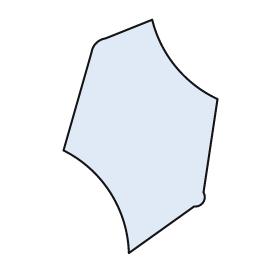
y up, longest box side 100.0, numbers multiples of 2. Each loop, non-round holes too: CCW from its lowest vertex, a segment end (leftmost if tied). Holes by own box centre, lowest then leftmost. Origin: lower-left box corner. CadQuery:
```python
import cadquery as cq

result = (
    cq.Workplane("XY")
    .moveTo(28.0, 0.0)
    .lineTo(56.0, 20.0)
    .threePointArc((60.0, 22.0), (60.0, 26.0))
    .lineTo(66.0, 66.0)
    .threePointArc((48.0, 80.0), (38.0, 100.0))
    .lineTo(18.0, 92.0)
    .threePointArc((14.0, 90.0), (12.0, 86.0))
    .lineTo(0.0, 44.0)
    .threePointArc((20.0, 26.0), (28.0, 0.0))
    .close()
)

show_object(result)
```